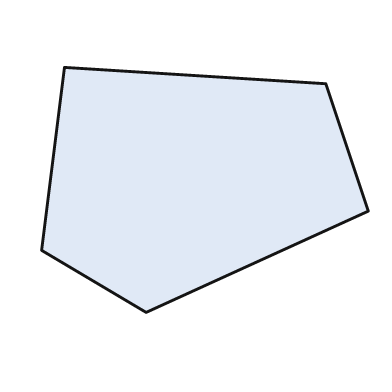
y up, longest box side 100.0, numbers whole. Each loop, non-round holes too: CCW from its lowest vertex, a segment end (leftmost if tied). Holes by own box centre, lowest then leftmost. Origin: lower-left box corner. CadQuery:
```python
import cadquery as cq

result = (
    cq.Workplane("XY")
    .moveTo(32.0, 0.0)
    .lineTo(100.0, 31.0)
    .lineTo(87.0, 70.0)
    .lineTo(7.0, 75.0)
    .lineTo(0.0, 19.0)
    .close()
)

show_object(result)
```